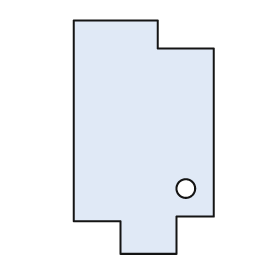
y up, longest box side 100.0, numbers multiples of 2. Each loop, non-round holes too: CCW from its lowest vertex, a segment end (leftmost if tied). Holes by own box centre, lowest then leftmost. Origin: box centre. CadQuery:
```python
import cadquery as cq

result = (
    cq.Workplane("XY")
    .moveTo(-10.0, -50.0)
    .lineTo(14.0, -50.0)
    .lineTo(14.0, -34.0)
    .lineTo(30.0, -34.0)
    .lineTo(30.0, 38.0)
    .lineTo(6.0, 38.0)
    .lineTo(6.0, 50.0)
    .lineTo(-30.0, 50.0)
    .lineTo(-30.0, -36.0)
    .lineTo(-10.0, -36.0)
    .close()
    .moveTo(18.0, -22.0)
    .circle(4.0)
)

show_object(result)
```